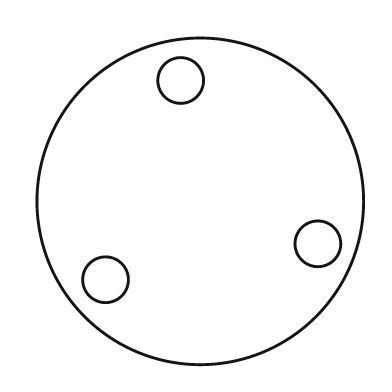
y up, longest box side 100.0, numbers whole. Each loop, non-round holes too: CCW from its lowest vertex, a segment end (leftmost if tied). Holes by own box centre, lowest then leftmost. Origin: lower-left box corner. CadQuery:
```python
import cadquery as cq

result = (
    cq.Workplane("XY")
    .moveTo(50.0, 50.0)
    .circle(50.0)
    .moveTo(21.0, 26.0)
    .circle(7.0)
    .moveTo(86.0, 37.0)
    .circle(7.0)
    .moveTo(44.0, 87.0)
    .circle(7.0)
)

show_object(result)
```